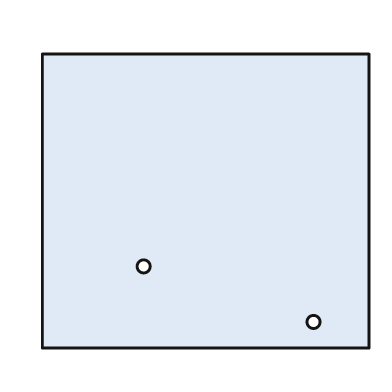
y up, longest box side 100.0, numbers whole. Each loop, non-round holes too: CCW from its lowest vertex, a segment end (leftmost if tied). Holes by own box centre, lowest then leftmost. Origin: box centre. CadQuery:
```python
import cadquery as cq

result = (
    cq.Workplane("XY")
    .moveTo(-50.0, -45.0)
    .lineTo(50.0, -45.0)
    .lineTo(50.0, 45.0)
    .lineTo(-50.0, 45.0)
    .close()
    .moveTo(33.0, -37.0)
    .circle(2.0)
    .moveTo(-19.0, -20.0)
    .circle(2.0)
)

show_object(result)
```